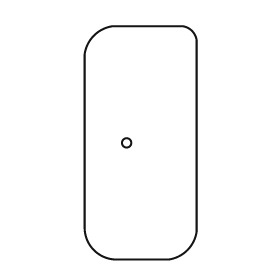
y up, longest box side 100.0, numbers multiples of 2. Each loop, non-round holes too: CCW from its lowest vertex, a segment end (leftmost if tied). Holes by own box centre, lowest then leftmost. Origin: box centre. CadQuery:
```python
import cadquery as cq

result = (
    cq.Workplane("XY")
    .moveTo(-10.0, -50.0)
    .lineTo(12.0, -50.0)
    .threePointArc((20.0, -46.0), (24.0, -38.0))
    .lineTo(24.0, 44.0)
    .threePointArc((22.0, 48.0), (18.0, 50.0))
    .lineTo(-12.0, 50.0)
    .threePointArc((-20.0, 46.0), (-24.0, 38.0))
    .lineTo(-24.0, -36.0)
    .threePointArc((-20.0, -46.0), (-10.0, -50.0))
    .close()
    .moveTo(-6.0, 0.0)
    .circle(2.0)
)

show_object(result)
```